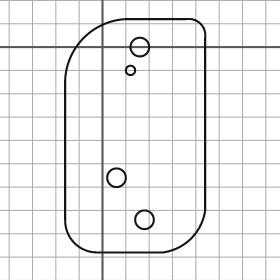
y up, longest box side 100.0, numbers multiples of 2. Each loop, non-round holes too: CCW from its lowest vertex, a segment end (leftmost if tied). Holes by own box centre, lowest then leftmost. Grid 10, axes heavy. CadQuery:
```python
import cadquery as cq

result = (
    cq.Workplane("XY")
    .moveTo(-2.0, -88.0)
    .lineTo(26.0, -88.0)
    .threePointArc((38.0, -82.0), (44.0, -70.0))
    .lineTo(44.0, 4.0)
    .threePointArc((42.0, 10.0), (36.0, 12.0))
    .lineTo(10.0, 12.0)
    .threePointArc((-8.0, 4.0), (-16.0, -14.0))
    .lineTo(-16.0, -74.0)
    .threePointArc((-12.0, -84.0), (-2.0, -88.0))
    .close()
    .moveTo(18.0, -74.0)
    .circle(4.0)
    .moveTo(6.0, -56.0)
    .circle(4.0)
    .moveTo(12.0, -10.0)
    .circle(2.0)
    .moveTo(16.0, 0.0)
    .circle(4.0)
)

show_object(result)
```